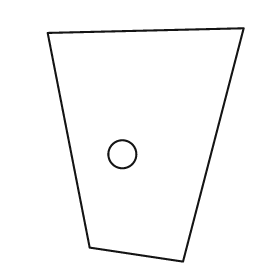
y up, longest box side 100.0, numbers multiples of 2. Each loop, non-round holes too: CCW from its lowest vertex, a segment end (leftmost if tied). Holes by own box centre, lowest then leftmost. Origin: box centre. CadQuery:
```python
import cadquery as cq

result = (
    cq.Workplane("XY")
    .moveTo(16.0, -50.0)
    .lineTo(42.0, 50.0)
    .lineTo(-42.0, 48.0)
    .lineTo(-24.0, -44.0)
    .close()
    .moveTo(-10.0, -4.0)
    .circle(6.0)
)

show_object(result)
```